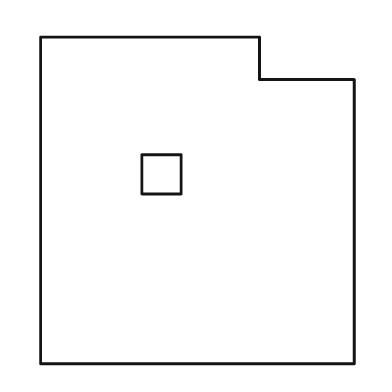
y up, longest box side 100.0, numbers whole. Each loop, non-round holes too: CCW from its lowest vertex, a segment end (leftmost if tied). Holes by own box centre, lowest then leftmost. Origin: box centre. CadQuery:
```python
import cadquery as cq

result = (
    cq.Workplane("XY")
    .moveTo(-48.0, -50.0)
    .lineTo(48.0, -50.0)
    .lineTo(48.0, 37.0)
    .lineTo(19.0, 37.0)
    .lineTo(19.0, 50.0)
    .lineTo(-48.0, 50.0)
    .close()
    .moveTo(-17.0, 2.0)
    .lineTo(-5.0, 2.0)
    .lineTo(-5.0, 14.0)
    .lineTo(-17.0, 14.0)
    .close()
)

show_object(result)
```